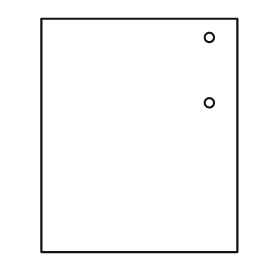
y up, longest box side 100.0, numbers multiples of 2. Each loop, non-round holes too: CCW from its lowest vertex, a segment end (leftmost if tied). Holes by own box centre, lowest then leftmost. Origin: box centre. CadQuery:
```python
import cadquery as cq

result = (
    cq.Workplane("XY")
    .moveTo(-42.0, -50.0)
    .lineTo(42.0, -50.0)
    .lineTo(42.0, 50.0)
    .lineTo(-42.0, 50.0)
    .close()
    .moveTo(30.0, 14.0)
    .circle(2.0)
    .moveTo(30.0, 42.0)
    .circle(2.0)
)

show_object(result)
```